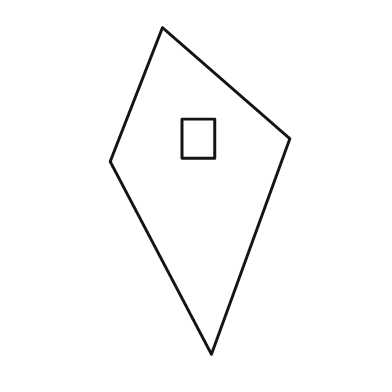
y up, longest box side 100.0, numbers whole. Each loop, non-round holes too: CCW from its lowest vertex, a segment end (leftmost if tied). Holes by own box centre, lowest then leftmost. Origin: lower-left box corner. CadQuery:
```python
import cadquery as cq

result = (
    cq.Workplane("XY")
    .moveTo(31.0, 0.0)
    .lineTo(55.0, 66.0)
    .lineTo(16.0, 100.0)
    .lineTo(0.0, 59.0)
    .close()
    .moveTo(22.0, 60.0)
    .lineTo(32.0, 60.0)
    .lineTo(32.0, 72.0)
    .lineTo(22.0, 72.0)
    .close()
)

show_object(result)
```